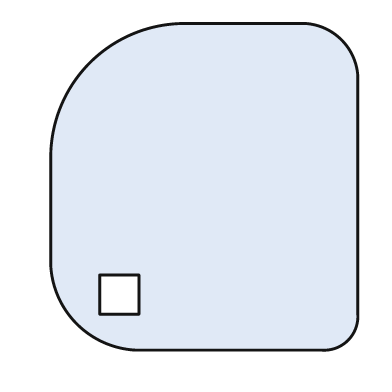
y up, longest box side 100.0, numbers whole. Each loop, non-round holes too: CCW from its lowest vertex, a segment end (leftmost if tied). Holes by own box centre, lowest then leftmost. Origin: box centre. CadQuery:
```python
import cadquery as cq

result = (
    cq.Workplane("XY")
    .moveTo(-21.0, -50.0)
    .lineTo(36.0, -50.0)
    .threePointArc((44.0, -47.0), (47.0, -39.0))
    .lineTo(47.0, 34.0)
    .threePointArc((42.0, 45.0), (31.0, 50.0))
    .lineTo(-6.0, 50.0)
    .threePointArc((-35.0, 38.0), (-47.0, 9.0))
    .lineTo(-47.0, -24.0)
    .threePointArc((-39.0, -42.0), (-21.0, -50.0))
    .close()
    .moveTo(-32.0, -39.0)
    .lineTo(-20.0, -39.0)
    .lineTo(-20.0, -27.0)
    .lineTo(-32.0, -27.0)
    .close()
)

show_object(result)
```